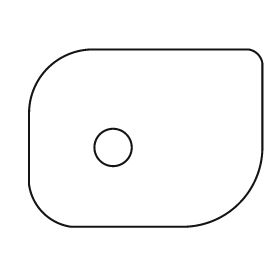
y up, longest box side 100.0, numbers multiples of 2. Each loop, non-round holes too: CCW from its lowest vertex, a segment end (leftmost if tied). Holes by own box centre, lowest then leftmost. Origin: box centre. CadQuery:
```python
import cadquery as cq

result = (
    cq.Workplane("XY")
    .moveTo(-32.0, -38.0)
    .lineTo(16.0, -38.0)
    .threePointArc((40.0, -28.0), (50.0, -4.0))
    .lineTo(50.0, 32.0)
    .threePointArc((48.0, 36.0), (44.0, 38.0))
    .lineTo(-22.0, 38.0)
    .threePointArc((-42.0, 30.0), (-50.0, 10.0))
    .lineTo(-50.0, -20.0)
    .threePointArc((-44.0, -32.0), (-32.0, -38.0))
    .close()
    .moveTo(-14.0, -4.0)
    .circle(8.0)
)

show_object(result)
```